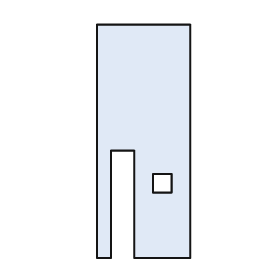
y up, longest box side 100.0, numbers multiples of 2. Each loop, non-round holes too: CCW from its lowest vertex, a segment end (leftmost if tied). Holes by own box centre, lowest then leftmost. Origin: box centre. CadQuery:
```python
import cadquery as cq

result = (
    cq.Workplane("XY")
    .moveTo(-20.0, -50.0)
    .lineTo(-14.0, -50.0)
    .lineTo(-14.0, -4.0)
    .lineTo(-4.0, -4.0)
    .lineTo(-4.0, -50.0)
    .lineTo(20.0, -50.0)
    .lineTo(20.0, 50.0)
    .lineTo(-20.0, 50.0)
    .close()
    .moveTo(4.0, -22.0)
    .lineTo(12.0, -22.0)
    .lineTo(12.0, -14.0)
    .lineTo(4.0, -14.0)
    .close()
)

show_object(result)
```